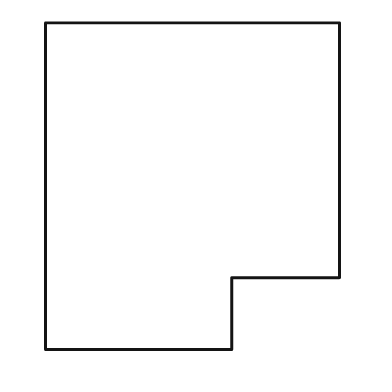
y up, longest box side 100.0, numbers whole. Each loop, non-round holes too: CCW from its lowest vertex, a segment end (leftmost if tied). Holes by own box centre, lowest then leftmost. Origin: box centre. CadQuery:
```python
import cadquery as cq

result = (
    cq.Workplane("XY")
    .moveTo(-45.0, -50.0)
    .lineTo(12.0, -50.0)
    .lineTo(12.0, -28.0)
    .lineTo(45.0, -28.0)
    .lineTo(45.0, 50.0)
    .lineTo(-45.0, 50.0)
    .close()
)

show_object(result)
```